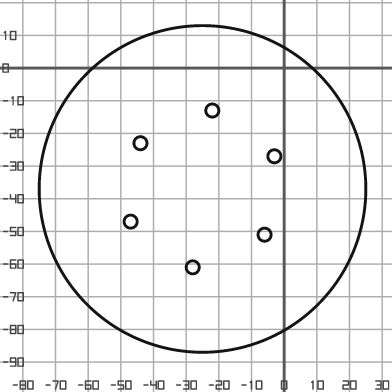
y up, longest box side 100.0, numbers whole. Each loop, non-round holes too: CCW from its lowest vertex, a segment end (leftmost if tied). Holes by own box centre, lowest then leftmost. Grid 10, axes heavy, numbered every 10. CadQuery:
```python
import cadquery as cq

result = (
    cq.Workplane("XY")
    .moveTo(-25.0, -37.0)
    .circle(50.0)
    .moveTo(-28.0, -61.0)
    .circle(2.0)
    .moveTo(-6.0, -51.0)
    .circle(2.0)
    .moveTo(-47.0, -47.0)
    .circle(2.0)
    .moveTo(-3.0, -27.0)
    .circle(2.0)
    .moveTo(-44.0, -23.0)
    .circle(2.0)
    .moveTo(-22.0, -13.0)
    .circle(2.0)
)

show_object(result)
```